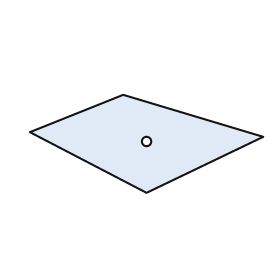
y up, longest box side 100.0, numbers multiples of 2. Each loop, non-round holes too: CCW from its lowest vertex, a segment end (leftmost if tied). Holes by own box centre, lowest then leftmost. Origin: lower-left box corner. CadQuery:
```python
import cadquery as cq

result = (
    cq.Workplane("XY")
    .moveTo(50.0, 0.0)
    .lineTo(100.0, 24.0)
    .lineTo(40.0, 42.0)
    .lineTo(0.0, 26.0)
    .close()
    .moveTo(50.0, 22.0)
    .circle(2.0)
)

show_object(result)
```